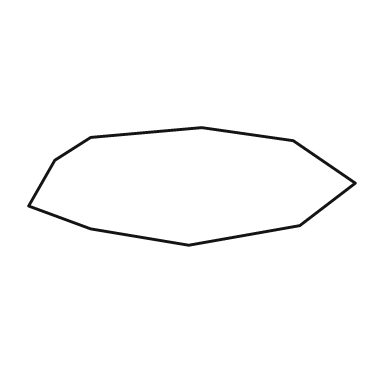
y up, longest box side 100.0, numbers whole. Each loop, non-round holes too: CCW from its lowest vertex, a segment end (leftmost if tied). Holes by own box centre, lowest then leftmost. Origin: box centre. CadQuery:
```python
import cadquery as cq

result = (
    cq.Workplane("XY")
    .moveTo(-1.0, -18.0)
    .lineTo(33.0, -12.0)
    .lineTo(50.0, 1.0)
    .lineTo(31.0, 14.0)
    .lineTo(3.0, 18.0)
    .lineTo(-31.0, 15.0)
    .lineTo(-42.0, 8.0)
    .lineTo(-50.0, -6.0)
    .lineTo(-31.0, -13.0)
    .close()
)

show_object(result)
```